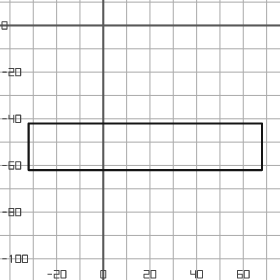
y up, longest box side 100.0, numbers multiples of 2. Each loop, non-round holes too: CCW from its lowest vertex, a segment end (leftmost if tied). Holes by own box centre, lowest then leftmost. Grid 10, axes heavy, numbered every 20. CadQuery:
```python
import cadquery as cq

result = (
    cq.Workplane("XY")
    .moveTo(-32.0, -62.0)
    .lineTo(68.0, -62.0)
    .lineTo(68.0, -42.0)
    .lineTo(-32.0, -42.0)
    .close()
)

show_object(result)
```